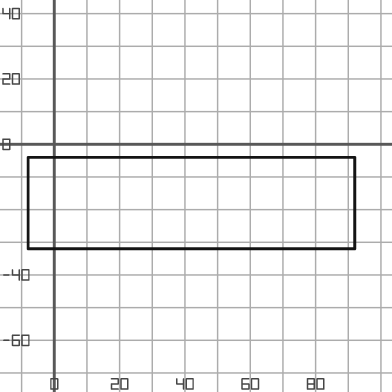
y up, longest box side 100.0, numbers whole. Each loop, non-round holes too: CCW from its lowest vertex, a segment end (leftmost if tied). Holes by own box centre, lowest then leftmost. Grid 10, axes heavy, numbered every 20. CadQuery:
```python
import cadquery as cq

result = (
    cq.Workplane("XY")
    .moveTo(-8.0, -32.0)
    .lineTo(92.0, -32.0)
    .lineTo(92.0, -4.0)
    .lineTo(-8.0, -4.0)
    .close()
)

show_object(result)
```